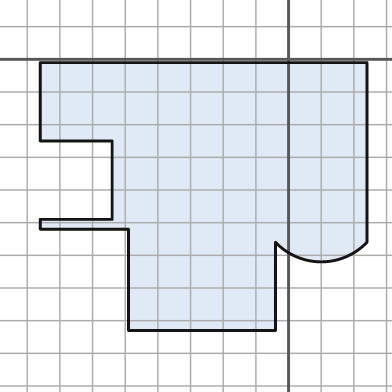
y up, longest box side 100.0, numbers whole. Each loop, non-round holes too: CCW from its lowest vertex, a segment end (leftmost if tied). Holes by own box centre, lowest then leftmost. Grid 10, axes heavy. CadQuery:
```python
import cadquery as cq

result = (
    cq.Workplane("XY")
    .moveTo(-49.0, -83.0)
    .lineTo(-4.0, -83.0)
    .lineTo(-4.0, -56.0)
    .threePointArc((10.0, -62.0), (24.0, -56.0))
    .lineTo(24.0, -1.0)
    .lineTo(-76.0, -1.0)
    .lineTo(-76.0, -25.0)
    .lineTo(-54.0, -25.0)
    .lineTo(-54.0, -49.0)
    .lineTo(-76.0, -49.0)
    .lineTo(-76.0, -52.0)
    .lineTo(-49.0, -52.0)
    .close()
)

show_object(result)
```